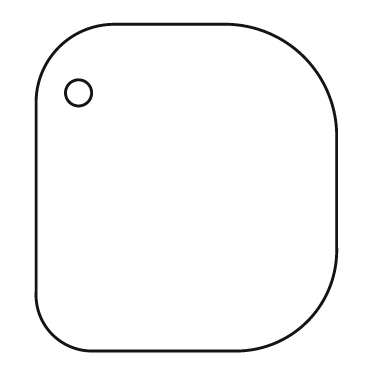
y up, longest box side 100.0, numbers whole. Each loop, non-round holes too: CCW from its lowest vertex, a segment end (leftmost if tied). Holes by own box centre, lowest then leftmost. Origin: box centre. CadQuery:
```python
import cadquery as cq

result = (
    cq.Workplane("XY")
    .moveTo(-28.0, -50.0)
    .lineTo(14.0, -50.0)
    .threePointArc((37.0, -41.0), (46.0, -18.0))
    .lineTo(46.0, 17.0)
    .threePointArc((36.0, 40.0), (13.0, 50.0))
    .lineTo(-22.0, 50.0)
    .threePointArc((-39.0, 43.0), (-46.0, 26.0))
    .lineTo(-46.0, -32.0)
    .threePointArc((-41.0, -45.0), (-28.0, -50.0))
    .close()
    .moveTo(-33.0, 29.0)
    .circle(4.0)
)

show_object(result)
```